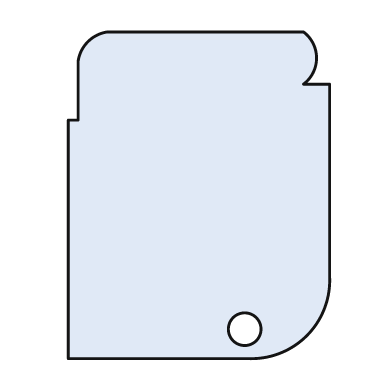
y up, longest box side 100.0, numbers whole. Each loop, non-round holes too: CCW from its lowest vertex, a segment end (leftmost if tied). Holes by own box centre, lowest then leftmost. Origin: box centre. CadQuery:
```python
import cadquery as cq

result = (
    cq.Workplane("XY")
    .moveTo(-40.0, -50.0)
    .lineTo(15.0, -50.0)
    .threePointArc((33.0, -43.0), (40.0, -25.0))
    .lineTo(40.0, 34.0)
    .lineTo(32.0, 34.0)
    .threePointArc((36.0, 42.0), (32.0, 50.0))
    .lineTo(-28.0, 50.0)
    .threePointArc((-34.0, 47.0), (-37.0, 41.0))
    .lineTo(-37.0, 23.0)
    .lineTo(-40.0, 23.0)
    .close()
    .moveTo(14.0, -41.0)
    .circle(5.0)
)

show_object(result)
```